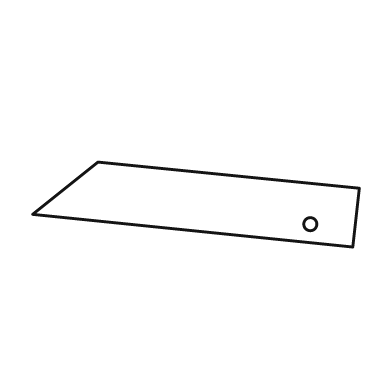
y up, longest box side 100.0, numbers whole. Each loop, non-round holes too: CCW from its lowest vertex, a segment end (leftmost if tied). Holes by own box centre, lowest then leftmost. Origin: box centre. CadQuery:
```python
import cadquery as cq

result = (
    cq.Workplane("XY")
    .moveTo(48.0, -13.0)
    .lineTo(50.0, 5.0)
    .lineTo(-30.0, 13.0)
    .lineTo(-50.0, -3.0)
    .close()
    .moveTo(35.0, -6.0)
    .circle(2.0)
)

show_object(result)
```